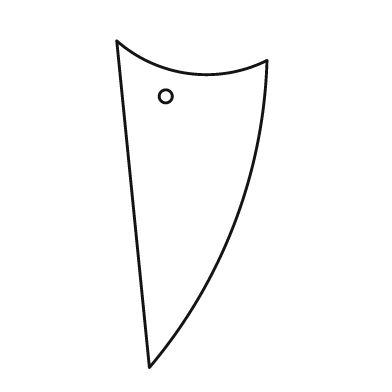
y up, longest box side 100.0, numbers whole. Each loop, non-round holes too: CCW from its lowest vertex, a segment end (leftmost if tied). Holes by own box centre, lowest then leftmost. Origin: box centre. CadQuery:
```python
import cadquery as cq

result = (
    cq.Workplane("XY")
    .moveTo(-13.0, -50.0)
    .threePointArc((13.0, -6.0), (23.0, 44.0))
    .threePointArc((-1.0, 40.0), (-23.0, 50.0))
    .close()
    .moveTo(-8.0, 33.0)
    .circle(2.0)
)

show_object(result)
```